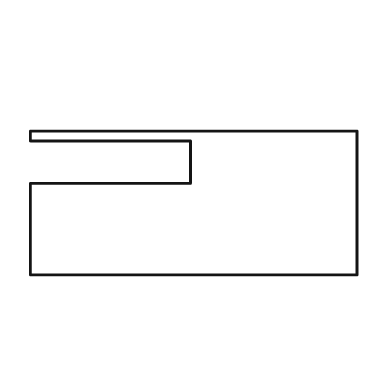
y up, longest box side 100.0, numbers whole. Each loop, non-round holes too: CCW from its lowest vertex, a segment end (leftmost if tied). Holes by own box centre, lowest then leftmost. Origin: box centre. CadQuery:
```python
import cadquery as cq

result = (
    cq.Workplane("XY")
    .moveTo(-50.0, -22.0)
    .lineTo(50.0, -22.0)
    .lineTo(50.0, 22.0)
    .lineTo(-50.0, 22.0)
    .lineTo(-50.0, 19.0)
    .lineTo(-1.0, 19.0)
    .lineTo(-1.0, 6.0)
    .lineTo(-50.0, 6.0)
    .close()
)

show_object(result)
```